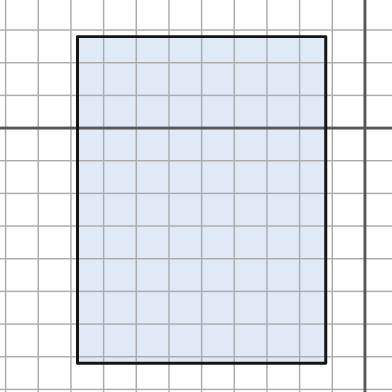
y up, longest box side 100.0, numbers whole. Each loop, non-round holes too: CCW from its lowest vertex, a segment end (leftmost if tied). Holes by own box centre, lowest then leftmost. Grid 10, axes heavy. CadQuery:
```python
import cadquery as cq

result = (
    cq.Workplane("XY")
    .moveTo(-88.0, -72.0)
    .lineTo(-12.0, -72.0)
    .lineTo(-12.0, 28.0)
    .lineTo(-88.0, 28.0)
    .close()
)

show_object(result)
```